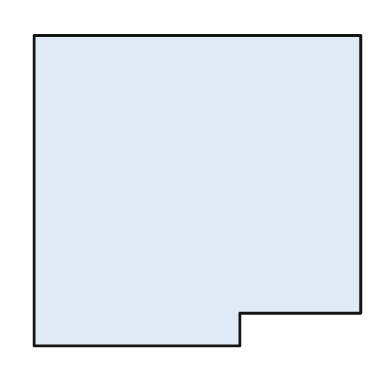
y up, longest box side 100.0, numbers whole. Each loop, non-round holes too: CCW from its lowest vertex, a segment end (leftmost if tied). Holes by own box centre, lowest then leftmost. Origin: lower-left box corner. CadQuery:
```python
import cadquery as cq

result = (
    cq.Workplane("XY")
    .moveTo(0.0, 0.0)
    .lineTo(63.0, 0.0)
    .lineTo(63.0, 10.0)
    .lineTo(100.0, 10.0)
    .lineTo(100.0, 95.0)
    .lineTo(0.0, 95.0)
    .close()
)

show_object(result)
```